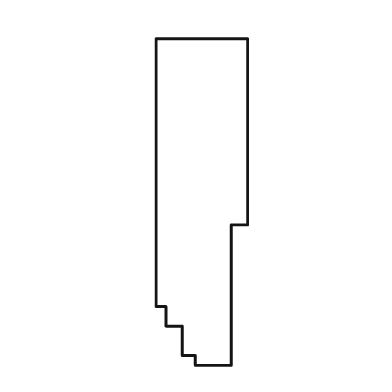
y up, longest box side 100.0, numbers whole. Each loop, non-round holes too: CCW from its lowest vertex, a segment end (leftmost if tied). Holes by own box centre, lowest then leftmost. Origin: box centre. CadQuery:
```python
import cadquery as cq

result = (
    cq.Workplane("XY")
    .moveTo(-2.0, -50.0)
    .lineTo(9.0, -50.0)
    .lineTo(9.0, -7.0)
    .lineTo(14.0, -7.0)
    .lineTo(14.0, 50.0)
    .lineTo(-14.0, 50.0)
    .lineTo(-14.0, -32.0)
    .lineTo(-11.0, -32.0)
    .lineTo(-11.0, -38.0)
    .lineTo(-6.0, -38.0)
    .lineTo(-6.0, -47.0)
    .lineTo(-2.0, -47.0)
    .close()
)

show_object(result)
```